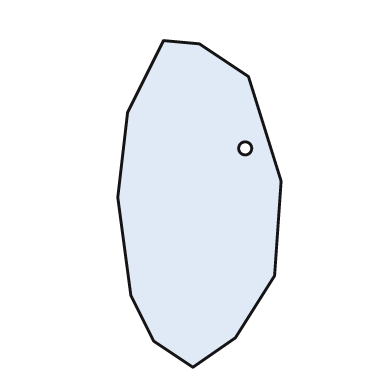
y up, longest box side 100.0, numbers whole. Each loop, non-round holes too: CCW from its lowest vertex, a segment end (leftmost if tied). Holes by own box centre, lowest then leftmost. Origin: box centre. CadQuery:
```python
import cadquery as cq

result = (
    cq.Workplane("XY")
    .moveTo(-2.0, -50.0)
    .lineTo(11.0, -41.0)
    .lineTo(23.0, -22.0)
    .lineTo(25.0, 7.0)
    .lineTo(15.0, 39.0)
    .lineTo(0.0, 49.0)
    .lineTo(-11.0, 50.0)
    .lineTo(-22.0, 28.0)
    .lineTo(-25.0, 2.0)
    .lineTo(-21.0, -28.0)
    .lineTo(-14.0, -42.0)
    .close()
    .moveTo(14.0, 17.0)
    .circle(2.0)
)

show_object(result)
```